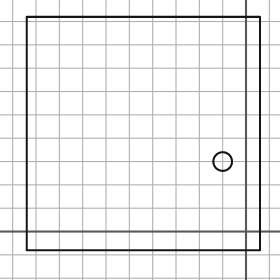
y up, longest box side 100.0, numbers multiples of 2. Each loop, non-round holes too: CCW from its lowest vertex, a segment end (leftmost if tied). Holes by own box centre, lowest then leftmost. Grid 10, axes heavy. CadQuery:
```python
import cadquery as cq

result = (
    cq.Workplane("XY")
    .moveTo(-94.0, -8.0)
    .lineTo(6.0, -8.0)
    .lineTo(6.0, 92.0)
    .lineTo(-94.0, 92.0)
    .close()
    .moveTo(-10.0, 30.0)
    .circle(4.0)
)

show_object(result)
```